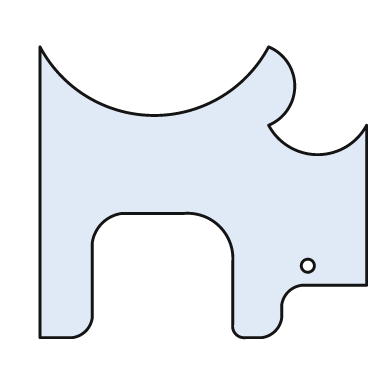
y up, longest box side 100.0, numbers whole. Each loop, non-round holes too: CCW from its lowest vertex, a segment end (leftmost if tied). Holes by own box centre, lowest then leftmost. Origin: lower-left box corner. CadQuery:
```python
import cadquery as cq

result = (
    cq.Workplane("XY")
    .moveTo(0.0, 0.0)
    .lineTo(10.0, 0.0)
    .threePointArc((14.0, 2.0), (16.0, 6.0))
    .lineTo(16.0, 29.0)
    .threePointArc((19.0, 35.0), (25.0, 38.0))
    .lineTo(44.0, 38.0)
    .threePointArc((55.0, 34.0), (59.0, 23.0))
    .lineTo(59.0, 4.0)
    .threePointArc((60.0, 1.0), (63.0, 0.0))
    .lineTo(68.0, 0.0)
    .threePointArc((72.0, 2.0), (74.0, 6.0))
    .lineTo(74.0, 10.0)
    .threePointArc((76.0, 14.0), (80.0, 16.0))
    .lineTo(100.0, 16.0)
    .lineTo(100.0, 65.0)
    .threePointArc((85.0, 56.0), (70.0, 65.0))
    .threePointArc((78.0, 77.0), (70.0, 89.0))
    .threePointArc((35.0, 68.0), (0.0, 89.0))
    .close()
    .moveTo(82.0, 22.0)
    .circle(2.0)
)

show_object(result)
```